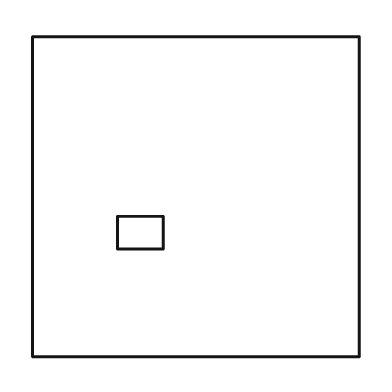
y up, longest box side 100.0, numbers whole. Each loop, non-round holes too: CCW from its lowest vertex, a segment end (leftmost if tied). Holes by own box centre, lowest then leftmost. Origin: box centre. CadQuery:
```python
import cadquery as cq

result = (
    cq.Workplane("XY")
    .moveTo(-50.0, -49.0)
    .lineTo(50.0, -49.0)
    .lineTo(50.0, 49.0)
    .lineTo(-50.0, 49.0)
    .close()
    .moveTo(-24.0, -16.0)
    .lineTo(-10.0, -16.0)
    .lineTo(-10.0, -6.0)
    .lineTo(-24.0, -6.0)
    .close()
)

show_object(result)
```